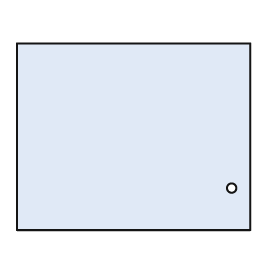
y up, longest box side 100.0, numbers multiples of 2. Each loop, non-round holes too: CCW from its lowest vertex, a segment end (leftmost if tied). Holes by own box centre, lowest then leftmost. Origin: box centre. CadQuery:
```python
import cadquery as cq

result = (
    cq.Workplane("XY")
    .moveTo(-50.0, -40.0)
    .lineTo(50.0, -40.0)
    .lineTo(50.0, 40.0)
    .lineTo(-50.0, 40.0)
    .close()
    .moveTo(42.0, -22.0)
    .circle(2.0)
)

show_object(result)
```